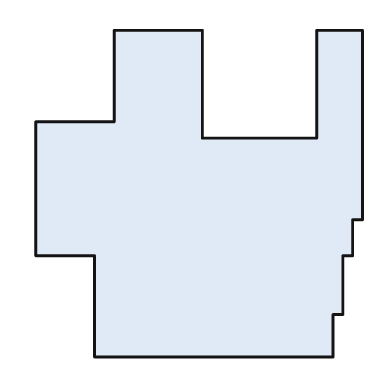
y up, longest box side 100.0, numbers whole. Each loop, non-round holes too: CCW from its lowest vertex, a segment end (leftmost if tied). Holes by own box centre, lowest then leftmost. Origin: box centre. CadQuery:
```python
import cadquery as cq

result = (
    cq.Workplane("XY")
    .moveTo(-32.0, -50.0)
    .lineTo(41.0, -50.0)
    .lineTo(41.0, -37.0)
    .lineTo(44.0, -37.0)
    .lineTo(44.0, -19.0)
    .lineTo(47.0, -19.0)
    .lineTo(47.0, -8.0)
    .lineTo(50.0, -8.0)
    .lineTo(50.0, 50.0)
    .lineTo(36.0, 50.0)
    .lineTo(36.0, 17.0)
    .lineTo(1.0, 17.0)
    .lineTo(1.0, 50.0)
    .lineTo(-26.0, 50.0)
    .lineTo(-26.0, 22.0)
    .lineTo(-50.0, 22.0)
    .lineTo(-50.0, -19.0)
    .lineTo(-32.0, -19.0)
    .close()
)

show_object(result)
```